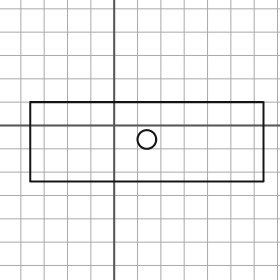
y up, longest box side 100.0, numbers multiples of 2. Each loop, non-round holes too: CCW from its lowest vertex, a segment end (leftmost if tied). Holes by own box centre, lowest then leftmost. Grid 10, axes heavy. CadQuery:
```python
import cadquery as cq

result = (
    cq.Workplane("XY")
    .moveTo(-36.0, -24.0)
    .lineTo(64.0, -24.0)
    .lineTo(64.0, 10.0)
    .lineTo(-36.0, 10.0)
    .close()
    .moveTo(14.0, -6.0)
    .circle(4.0)
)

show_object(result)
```